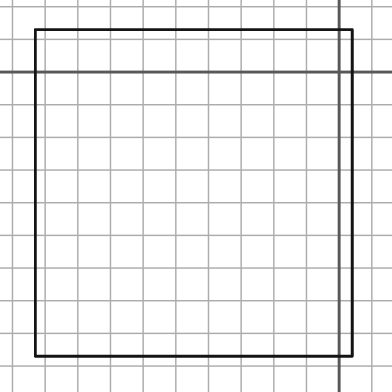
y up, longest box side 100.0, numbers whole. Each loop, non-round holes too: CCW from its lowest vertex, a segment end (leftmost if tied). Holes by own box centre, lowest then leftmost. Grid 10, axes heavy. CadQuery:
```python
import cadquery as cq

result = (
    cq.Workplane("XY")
    .moveTo(-93.0, -87.0)
    .lineTo(4.0, -87.0)
    .lineTo(4.0, 13.0)
    .lineTo(-93.0, 13.0)
    .close()
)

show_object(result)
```